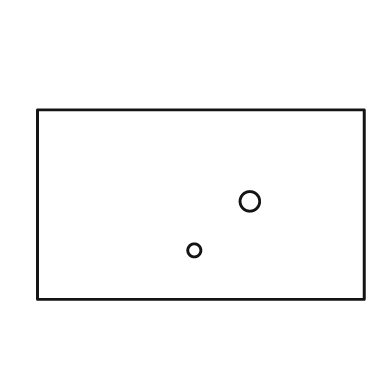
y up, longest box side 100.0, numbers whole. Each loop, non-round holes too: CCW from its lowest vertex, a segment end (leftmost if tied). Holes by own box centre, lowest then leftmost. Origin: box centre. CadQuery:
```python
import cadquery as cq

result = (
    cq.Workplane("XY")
    .moveTo(-50.0, -29.0)
    .lineTo(50.0, -29.0)
    .lineTo(50.0, 29.0)
    .lineTo(-50.0, 29.0)
    .close()
    .moveTo(-2.0, -14.0)
    .circle(2.0)
    .moveTo(15.0, 1.0)
    .circle(3.0)
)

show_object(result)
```